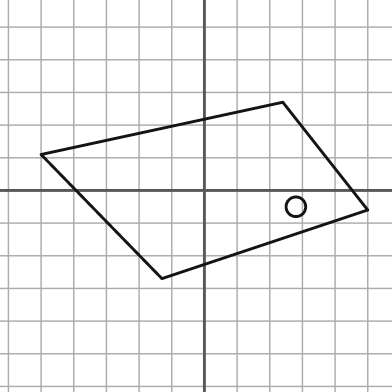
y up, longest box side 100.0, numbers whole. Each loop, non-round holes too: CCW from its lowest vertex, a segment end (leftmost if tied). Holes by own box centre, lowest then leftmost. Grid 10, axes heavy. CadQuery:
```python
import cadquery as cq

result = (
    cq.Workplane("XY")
    .moveTo(-13.0, -27.0)
    .lineTo(50.0, -6.0)
    .lineTo(24.0, 27.0)
    .lineTo(-50.0, 11.0)
    .close()
    .moveTo(28.0, -5.0)
    .circle(3.0)
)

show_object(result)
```